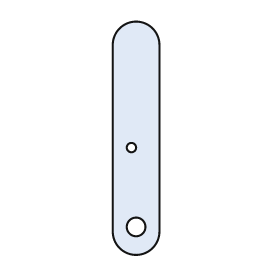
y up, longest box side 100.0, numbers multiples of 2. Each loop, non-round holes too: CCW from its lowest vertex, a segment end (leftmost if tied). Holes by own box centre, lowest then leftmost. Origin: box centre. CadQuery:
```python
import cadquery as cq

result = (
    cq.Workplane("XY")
    .moveTo(-10.0, -40.0)
    .threePointArc((0.0, -50.0), (10.0, -40.0))
    .lineTo(10.0, 40.0)
    .threePointArc((0.0, 50.0), (-10.0, 40.0))
    .close()
    .moveTo(0.0, -38.0)
    .circle(4.0)
    .moveTo(-2.0, -4.0)
    .circle(2.0)
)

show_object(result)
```